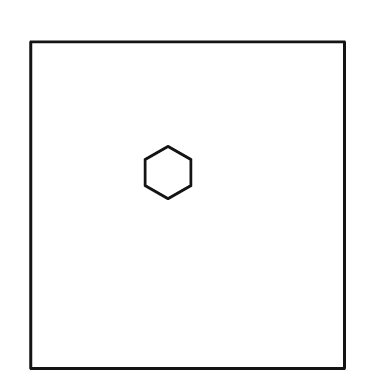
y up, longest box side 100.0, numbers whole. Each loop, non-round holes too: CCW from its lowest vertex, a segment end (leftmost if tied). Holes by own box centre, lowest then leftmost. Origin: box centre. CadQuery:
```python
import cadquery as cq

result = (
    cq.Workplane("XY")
    .moveTo(-48.0, -50.0)
    .lineTo(48.0, -50.0)
    .lineTo(48.0, 50.0)
    .lineTo(-48.0, 50.0)
    .close()
    .moveTo(-6.0, 2.0)
    .lineTo(1.0, 6.0)
    .lineTo(1.0, 14.0)
    .lineTo(-6.0, 18.0)
    .lineTo(-13.0, 14.0)
    .lineTo(-13.0, 6.0)
    .close()
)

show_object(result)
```